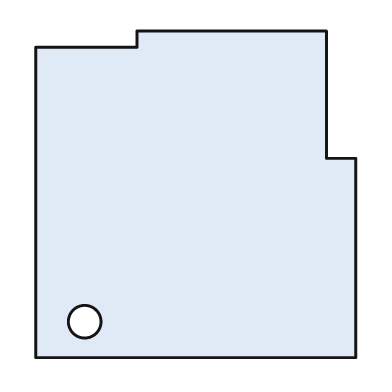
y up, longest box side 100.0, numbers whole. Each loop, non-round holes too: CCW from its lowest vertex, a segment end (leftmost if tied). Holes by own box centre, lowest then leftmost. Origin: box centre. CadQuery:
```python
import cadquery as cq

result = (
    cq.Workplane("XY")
    .moveTo(-49.0, -50.0)
    .lineTo(49.0, -50.0)
    .lineTo(49.0, 11.0)
    .lineTo(40.0, 11.0)
    .lineTo(40.0, 50.0)
    .lineTo(-18.0, 50.0)
    .lineTo(-18.0, 45.0)
    .lineTo(-49.0, 45.0)
    .close()
    .moveTo(-34.0, -39.0)
    .circle(5.0)
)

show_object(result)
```